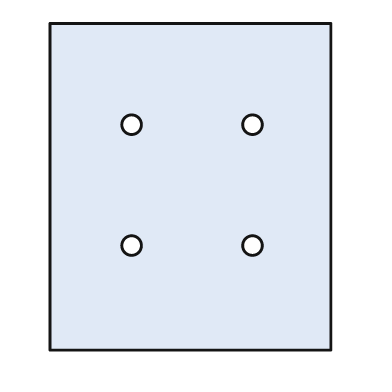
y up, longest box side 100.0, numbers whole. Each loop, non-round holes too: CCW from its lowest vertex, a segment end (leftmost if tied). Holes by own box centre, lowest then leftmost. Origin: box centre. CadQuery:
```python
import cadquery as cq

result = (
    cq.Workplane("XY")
    .moveTo(-43.0, -50.0)
    .lineTo(43.0, -50.0)
    .lineTo(43.0, 50.0)
    .lineTo(-43.0, 50.0)
    .close()
    .moveTo(-18.0, -18.0)
    .circle(3.0)
    .moveTo(19.0, -18.0)
    .circle(3.0)
    .moveTo(-18.0, 19.0)
    .circle(3.0)
    .moveTo(19.0, 19.0)
    .circle(3.0)
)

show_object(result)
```